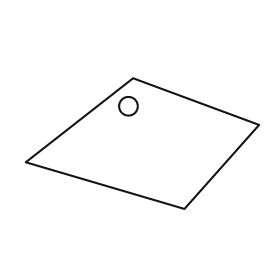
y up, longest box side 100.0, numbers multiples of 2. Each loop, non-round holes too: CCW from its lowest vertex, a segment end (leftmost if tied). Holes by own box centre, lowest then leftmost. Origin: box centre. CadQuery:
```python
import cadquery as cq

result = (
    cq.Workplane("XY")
    .moveTo(18.0, -28.0)
    .lineTo(50.0, 8.0)
    .lineTo(-4.0, 28.0)
    .lineTo(-50.0, -8.0)
    .close()
    .moveTo(-6.0, 16.0)
    .circle(4.0)
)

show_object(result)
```